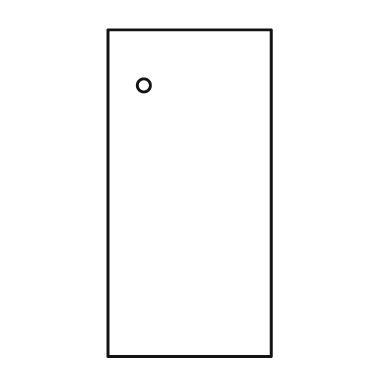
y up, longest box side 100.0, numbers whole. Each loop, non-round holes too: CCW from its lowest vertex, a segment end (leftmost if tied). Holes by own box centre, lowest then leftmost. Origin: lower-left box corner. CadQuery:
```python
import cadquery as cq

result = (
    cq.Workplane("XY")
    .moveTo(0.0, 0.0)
    .lineTo(50.0, 0.0)
    .lineTo(50.0, 100.0)
    .lineTo(0.0, 100.0)
    .close()
    .moveTo(11.0, 83.0)
    .circle(2.0)
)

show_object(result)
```